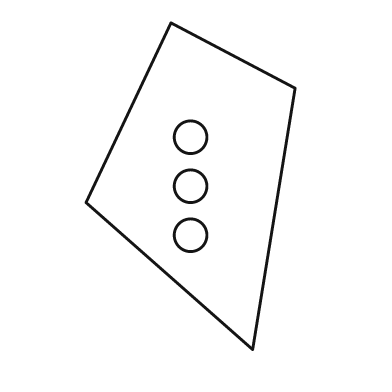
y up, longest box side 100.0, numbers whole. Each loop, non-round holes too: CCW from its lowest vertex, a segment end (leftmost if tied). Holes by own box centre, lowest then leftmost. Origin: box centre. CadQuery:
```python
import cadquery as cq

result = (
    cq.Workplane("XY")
    .moveTo(19.0, -50.0)
    .lineTo(32.0, 30.0)
    .lineTo(-6.0, 50.0)
    .lineTo(-32.0, -5.0)
    .close()
    .moveTo(0.0, -15.0)
    .circle(5.0)
    .moveTo(0.0, 0.0)
    .circle(5.0)
    .moveTo(0.0, 15.0)
    .circle(5.0)
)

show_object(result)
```